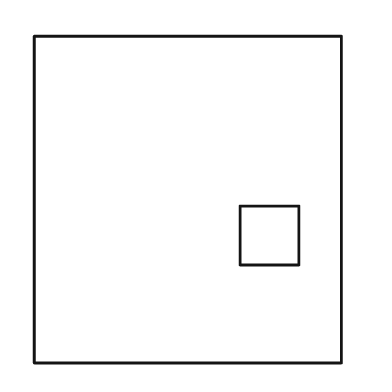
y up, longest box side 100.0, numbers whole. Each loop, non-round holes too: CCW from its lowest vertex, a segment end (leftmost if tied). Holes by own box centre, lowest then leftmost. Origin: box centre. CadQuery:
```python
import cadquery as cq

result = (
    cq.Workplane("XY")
    .moveTo(-47.0, -50.0)
    .lineTo(47.0, -50.0)
    .lineTo(47.0, 50.0)
    .lineTo(-47.0, 50.0)
    .close()
    .moveTo(16.0, -20.0)
    .lineTo(34.0, -20.0)
    .lineTo(34.0, -2.0)
    .lineTo(16.0, -2.0)
    .close()
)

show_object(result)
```